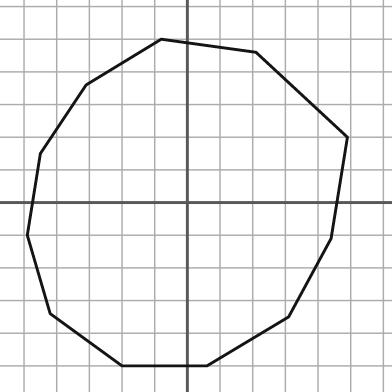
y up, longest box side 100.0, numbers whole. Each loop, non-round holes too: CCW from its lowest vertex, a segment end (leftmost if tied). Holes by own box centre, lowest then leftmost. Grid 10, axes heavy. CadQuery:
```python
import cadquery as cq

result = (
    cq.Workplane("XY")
    .moveTo(-20.0, -50.0)
    .lineTo(6.0, -50.0)
    .lineTo(31.0, -35.0)
    .lineTo(44.0, -11.0)
    .lineTo(49.0, 20.0)
    .lineTo(21.0, 46.0)
    .lineTo(-8.0, 50.0)
    .lineTo(-31.0, 36.0)
    .lineTo(-45.0, 15.0)
    .lineTo(-49.0, -10.0)
    .lineTo(-42.0, -34.0)
    .close()
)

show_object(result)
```